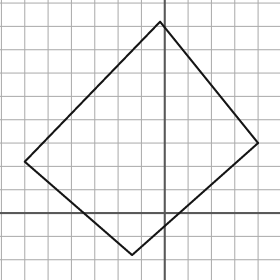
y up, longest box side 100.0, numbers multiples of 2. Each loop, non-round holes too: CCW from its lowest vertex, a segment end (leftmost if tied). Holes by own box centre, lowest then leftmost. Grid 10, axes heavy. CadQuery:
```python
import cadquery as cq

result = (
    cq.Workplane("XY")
    .moveTo(-14.0, -18.0)
    .lineTo(40.0, 30.0)
    .lineTo(-2.0, 82.0)
    .lineTo(-60.0, 22.0)
    .close()
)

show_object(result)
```